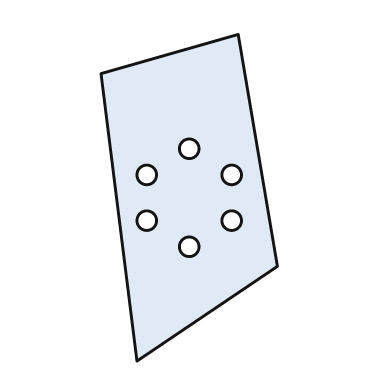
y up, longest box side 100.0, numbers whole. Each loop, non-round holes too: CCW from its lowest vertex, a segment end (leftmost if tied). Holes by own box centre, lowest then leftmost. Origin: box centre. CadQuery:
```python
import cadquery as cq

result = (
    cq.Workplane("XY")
    .moveTo(-16.0, -50.0)
    .lineTo(27.0, -21.0)
    .lineTo(15.0, 50.0)
    .lineTo(-27.0, 38.0)
    .close()
    .moveTo(0.0, -15.0)
    .circle(3.0)
    .moveTo(-13.0, -7.0)
    .circle(3.0)
    .moveTo(13.0, -7.0)
    .circle(3.0)
    .moveTo(-13.0, 7.0)
    .circle(3.0)
    .moveTo(13.0, 7.0)
    .circle(3.0)
    .moveTo(0.0, 15.0)
    .circle(3.0)
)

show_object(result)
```